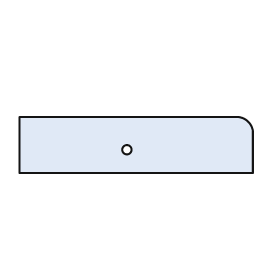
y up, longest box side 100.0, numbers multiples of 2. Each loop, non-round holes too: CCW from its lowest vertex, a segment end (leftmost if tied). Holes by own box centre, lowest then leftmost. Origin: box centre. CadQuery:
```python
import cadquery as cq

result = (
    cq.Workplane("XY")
    .moveTo(-50.0, -12.0)
    .lineTo(50.0, -12.0)
    .lineTo(50.0, 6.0)
    .threePointArc((48.0, 10.0), (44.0, 12.0))
    .lineTo(-50.0, 12.0)
    .close()
    .moveTo(-4.0, -2.0)
    .circle(2.0)
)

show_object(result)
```